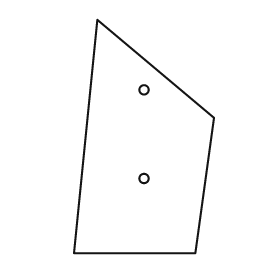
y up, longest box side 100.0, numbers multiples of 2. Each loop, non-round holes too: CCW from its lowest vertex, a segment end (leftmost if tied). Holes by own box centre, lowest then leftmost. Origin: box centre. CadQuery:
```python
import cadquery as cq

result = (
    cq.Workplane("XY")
    .moveTo(-30.0, -50.0)
    .lineTo(22.0, -50.0)
    .lineTo(30.0, 8.0)
    .lineTo(-20.0, 50.0)
    .close()
    .moveTo(0.0, -18.0)
    .circle(2.0)
    .moveTo(0.0, 20.0)
    .circle(2.0)
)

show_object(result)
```